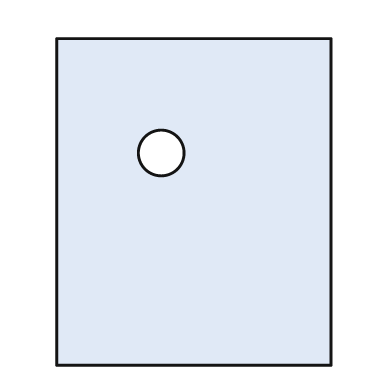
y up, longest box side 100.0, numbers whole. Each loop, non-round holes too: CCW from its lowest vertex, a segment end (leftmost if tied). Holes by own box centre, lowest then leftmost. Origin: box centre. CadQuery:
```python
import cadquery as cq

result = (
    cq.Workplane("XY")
    .moveTo(-42.0, -50.0)
    .lineTo(42.0, -50.0)
    .lineTo(42.0, 50.0)
    .lineTo(-42.0, 50.0)
    .close()
    .moveTo(-10.0, 15.0)
    .circle(7.0)
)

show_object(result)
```